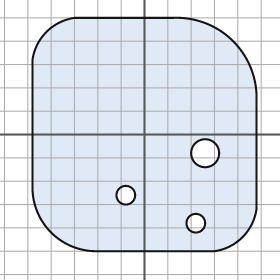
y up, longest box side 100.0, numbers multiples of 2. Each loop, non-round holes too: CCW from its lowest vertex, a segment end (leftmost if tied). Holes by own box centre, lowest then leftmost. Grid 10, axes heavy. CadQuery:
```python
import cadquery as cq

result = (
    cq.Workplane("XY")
    .moveTo(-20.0, -50.0)
    .lineTo(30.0, -50.0)
    .threePointArc((42.0, -44.0), (48.0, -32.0))
    .lineTo(48.0, 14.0)
    .threePointArc((38.0, 40.0), (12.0, 50.0))
    .lineTo(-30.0, 50.0)
    .threePointArc((-42.0, 44.0), (-48.0, 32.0))
    .lineTo(-48.0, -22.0)
    .threePointArc((-40.0, -42.0), (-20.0, -50.0))
    .close()
    .moveTo(22.0, -38.0)
    .circle(4.0)
    .moveTo(-8.0, -26.0)
    .circle(4.0)
    .moveTo(26.0, -8.0)
    .circle(6.0)
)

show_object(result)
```